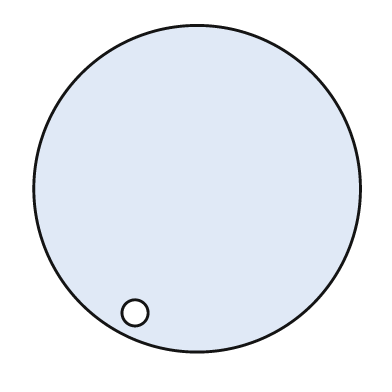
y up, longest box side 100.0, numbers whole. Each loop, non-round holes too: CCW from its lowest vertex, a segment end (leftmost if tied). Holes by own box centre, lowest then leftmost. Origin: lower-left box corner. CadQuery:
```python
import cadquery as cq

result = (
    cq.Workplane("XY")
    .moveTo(50.0, 50.0)
    .circle(50.0)
    .moveTo(31.0, 12.0)
    .circle(4.0)
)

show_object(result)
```